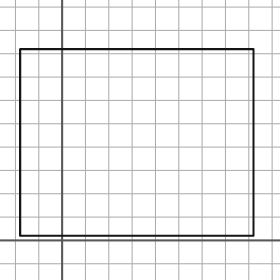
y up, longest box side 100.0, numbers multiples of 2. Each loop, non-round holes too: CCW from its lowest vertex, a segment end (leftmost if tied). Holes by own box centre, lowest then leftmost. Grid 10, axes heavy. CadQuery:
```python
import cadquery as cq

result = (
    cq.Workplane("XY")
    .moveTo(-18.0, 2.0)
    .lineTo(82.0, 2.0)
    .lineTo(82.0, 82.0)
    .lineTo(-18.0, 82.0)
    .close()
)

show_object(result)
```